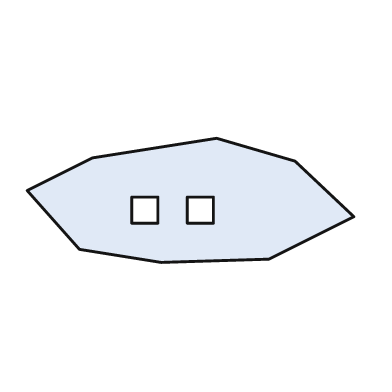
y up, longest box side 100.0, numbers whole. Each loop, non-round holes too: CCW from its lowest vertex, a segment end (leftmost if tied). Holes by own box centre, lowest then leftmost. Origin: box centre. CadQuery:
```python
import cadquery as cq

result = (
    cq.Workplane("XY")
    .moveTo(-9.0, -19.0)
    .lineTo(24.0, -18.0)
    .lineTo(50.0, -5.0)
    .lineTo(32.0, 12.0)
    .lineTo(8.0, 19.0)
    .lineTo(-30.0, 13.0)
    .lineTo(-50.0, 3.0)
    .lineTo(-34.0, -15.0)
    .close()
    .moveTo(-18.0, -7.0)
    .lineTo(-10.0, -7.0)
    .lineTo(-10.0, 1.0)
    .lineTo(-18.0, 1.0)
    .close()
    .moveTo(-1.0, -7.0)
    .lineTo(7.0, -7.0)
    .lineTo(7.0, 1.0)
    .lineTo(-1.0, 1.0)
    .close()
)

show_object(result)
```